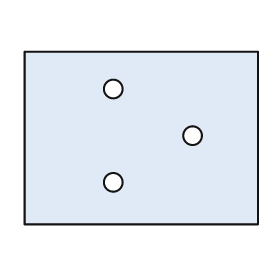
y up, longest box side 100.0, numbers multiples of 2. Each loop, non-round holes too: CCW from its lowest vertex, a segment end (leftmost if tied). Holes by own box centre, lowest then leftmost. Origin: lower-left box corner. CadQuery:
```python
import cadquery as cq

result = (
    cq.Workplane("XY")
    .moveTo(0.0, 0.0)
    .lineTo(100.0, 0.0)
    .lineTo(100.0, 74.0)
    .lineTo(0.0, 74.0)
    .close()
    .moveTo(38.0, 18.0)
    .circle(4.0)
    .moveTo(72.0, 38.0)
    .circle(4.0)
    .moveTo(38.0, 58.0)
    .circle(4.0)
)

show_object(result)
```